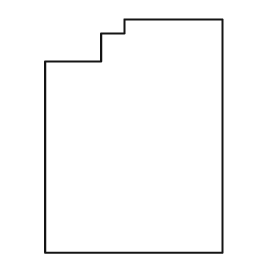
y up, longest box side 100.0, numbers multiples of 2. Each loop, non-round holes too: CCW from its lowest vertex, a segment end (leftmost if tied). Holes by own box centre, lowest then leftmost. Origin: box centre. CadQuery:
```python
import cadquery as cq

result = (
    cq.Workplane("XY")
    .moveTo(-38.0, -50.0)
    .lineTo(38.0, -50.0)
    .lineTo(38.0, 50.0)
    .lineTo(-4.0, 50.0)
    .lineTo(-4.0, 44.0)
    .lineTo(-14.0, 44.0)
    .lineTo(-14.0, 32.0)
    .lineTo(-38.0, 32.0)
    .close()
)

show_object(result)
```